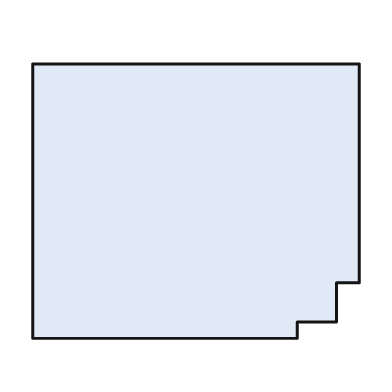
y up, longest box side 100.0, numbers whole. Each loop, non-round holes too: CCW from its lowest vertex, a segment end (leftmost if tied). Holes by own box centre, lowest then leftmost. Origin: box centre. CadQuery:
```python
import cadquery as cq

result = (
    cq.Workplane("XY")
    .moveTo(-50.0, -42.0)
    .lineTo(31.0, -42.0)
    .lineTo(31.0, -37.0)
    .lineTo(43.0, -37.0)
    .lineTo(43.0, -25.0)
    .lineTo(50.0, -25.0)
    .lineTo(50.0, 42.0)
    .lineTo(-50.0, 42.0)
    .close()
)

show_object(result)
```